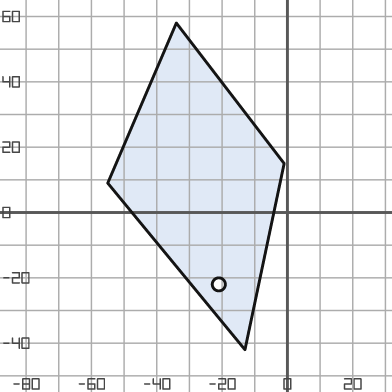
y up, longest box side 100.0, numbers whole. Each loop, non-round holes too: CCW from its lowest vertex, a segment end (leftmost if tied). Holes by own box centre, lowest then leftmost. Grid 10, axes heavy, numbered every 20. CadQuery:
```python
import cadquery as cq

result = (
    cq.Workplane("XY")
    .moveTo(-13.0, -42.0)
    .lineTo(-1.0, 15.0)
    .lineTo(-34.0, 58.0)
    .lineTo(-55.0, 9.0)
    .close()
    .moveTo(-21.0, -22.0)
    .circle(2.0)
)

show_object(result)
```